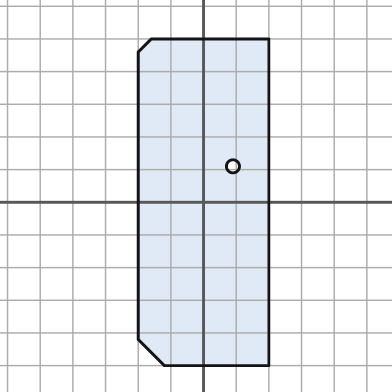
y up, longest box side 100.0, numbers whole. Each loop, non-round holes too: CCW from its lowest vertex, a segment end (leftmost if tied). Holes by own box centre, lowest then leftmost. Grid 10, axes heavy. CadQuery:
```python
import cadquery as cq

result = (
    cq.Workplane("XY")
    .moveTo(-12.0, -50.0)
    .lineTo(20.0, -50.0)
    .lineTo(20.0, 50.0)
    .lineTo(-16.0, 50.0)
    .lineTo(-20.0, 46.0)
    .lineTo(-20.0, -42.0)
    .close()
    .moveTo(9.0, 11.0)
    .circle(2.0)
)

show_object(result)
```